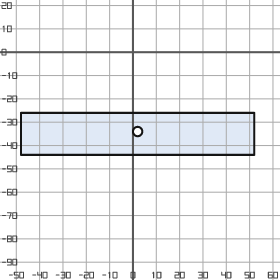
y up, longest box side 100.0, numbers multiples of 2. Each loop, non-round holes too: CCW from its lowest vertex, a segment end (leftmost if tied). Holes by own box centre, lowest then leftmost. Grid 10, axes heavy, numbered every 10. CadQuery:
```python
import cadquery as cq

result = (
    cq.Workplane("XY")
    .moveTo(-48.0, -44.0)
    .lineTo(52.0, -44.0)
    .lineTo(52.0, -26.0)
    .lineTo(-48.0, -26.0)
    .close()
    .moveTo(2.0, -34.0)
    .circle(2.0)
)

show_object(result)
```